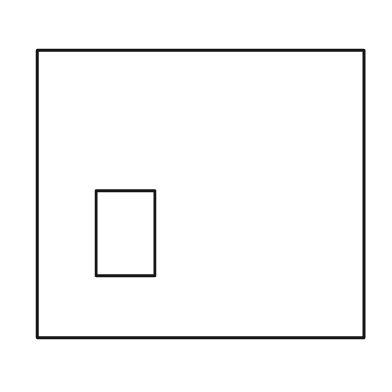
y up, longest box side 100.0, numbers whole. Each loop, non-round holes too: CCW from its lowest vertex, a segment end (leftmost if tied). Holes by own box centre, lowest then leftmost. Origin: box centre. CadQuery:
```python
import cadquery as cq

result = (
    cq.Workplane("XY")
    .moveTo(-50.0, -44.0)
    .lineTo(50.0, -44.0)
    .lineTo(50.0, 44.0)
    .lineTo(-50.0, 44.0)
    .close()
    .moveTo(-32.0, -25.0)
    .lineTo(-14.0, -25.0)
    .lineTo(-14.0, 1.0)
    .lineTo(-32.0, 1.0)
    .close()
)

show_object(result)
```